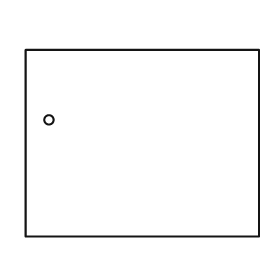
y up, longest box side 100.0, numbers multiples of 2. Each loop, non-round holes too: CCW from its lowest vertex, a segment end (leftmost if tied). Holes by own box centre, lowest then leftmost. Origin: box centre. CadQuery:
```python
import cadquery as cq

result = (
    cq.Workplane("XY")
    .moveTo(-50.0, -40.0)
    .lineTo(50.0, -40.0)
    .lineTo(50.0, 40.0)
    .lineTo(-50.0, 40.0)
    .close()
    .moveTo(-40.0, 10.0)
    .circle(2.0)
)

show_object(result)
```